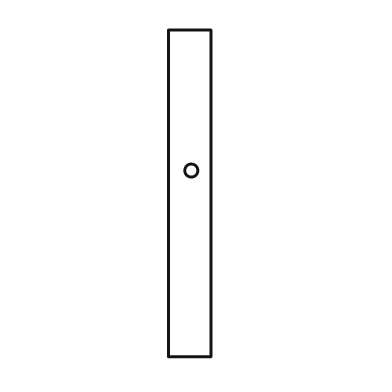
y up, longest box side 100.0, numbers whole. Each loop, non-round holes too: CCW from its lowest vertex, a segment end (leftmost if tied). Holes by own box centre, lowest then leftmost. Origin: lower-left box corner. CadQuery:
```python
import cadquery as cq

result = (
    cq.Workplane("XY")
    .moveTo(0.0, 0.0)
    .lineTo(13.0, 0.0)
    .lineTo(13.0, 100.0)
    .lineTo(0.0, 100.0)
    .close()
    .moveTo(7.0, 57.0)
    .circle(2.0)
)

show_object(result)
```